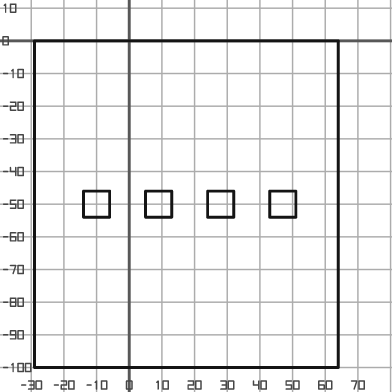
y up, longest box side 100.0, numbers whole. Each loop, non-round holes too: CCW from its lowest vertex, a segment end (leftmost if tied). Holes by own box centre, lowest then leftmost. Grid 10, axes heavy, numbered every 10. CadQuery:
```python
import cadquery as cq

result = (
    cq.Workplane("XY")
    .moveTo(-29.0, -100.0)
    .lineTo(64.0, -100.0)
    .lineTo(64.0, 0.0)
    .lineTo(-29.0, 0.0)
    .close()
    .moveTo(-14.0, -54.0)
    .lineTo(-6.0, -54.0)
    .lineTo(-6.0, -46.0)
    .lineTo(-14.0, -46.0)
    .close()
    .moveTo(5.0, -54.0)
    .lineTo(13.0, -54.0)
    .lineTo(13.0, -46.0)
    .lineTo(5.0, -46.0)
    .close()
    .moveTo(24.0, -54.0)
    .lineTo(32.0, -54.0)
    .lineTo(32.0, -46.0)
    .lineTo(24.0, -46.0)
    .close()
    .moveTo(43.0, -54.0)
    .lineTo(51.0, -54.0)
    .lineTo(51.0, -46.0)
    .lineTo(43.0, -46.0)
    .close()
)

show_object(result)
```